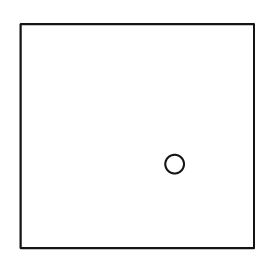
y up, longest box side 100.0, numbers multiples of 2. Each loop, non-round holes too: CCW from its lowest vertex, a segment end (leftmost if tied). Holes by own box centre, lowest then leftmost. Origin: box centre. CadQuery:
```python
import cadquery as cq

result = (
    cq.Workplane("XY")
    .moveTo(-50.0, -48.0)
    .lineTo(50.0, -48.0)
    .lineTo(50.0, 48.0)
    .lineTo(-50.0, 48.0)
    .close()
    .moveTo(16.0, -12.0)
    .circle(4.0)
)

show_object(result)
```